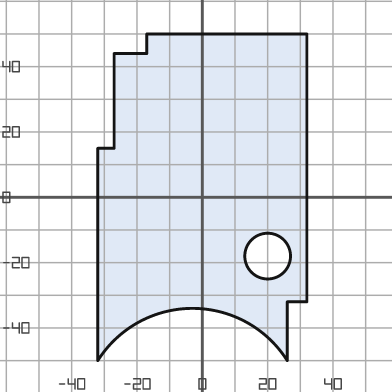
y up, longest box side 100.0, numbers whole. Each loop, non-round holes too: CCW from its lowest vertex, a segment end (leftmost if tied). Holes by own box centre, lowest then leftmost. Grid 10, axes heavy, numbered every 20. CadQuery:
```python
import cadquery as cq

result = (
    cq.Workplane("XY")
    .moveTo(-32.0, -50.0)
    .threePointArc((-3.0, -34.0), (26.0, -50.0))
    .lineTo(26.0, -32.0)
    .lineTo(32.0, -32.0)
    .lineTo(32.0, 50.0)
    .lineTo(-17.0, 50.0)
    .lineTo(-17.0, 44.0)
    .lineTo(-27.0, 44.0)
    .lineTo(-27.0, 15.0)
    .lineTo(-32.0, 15.0)
    .close()
    .moveTo(20.0, -18.0)
    .circle(7.0)
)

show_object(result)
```